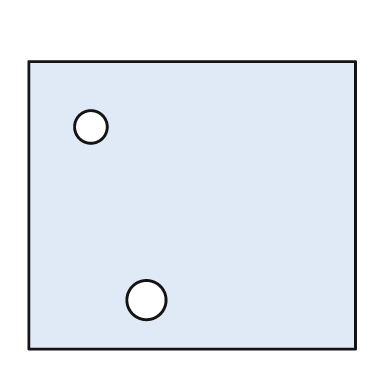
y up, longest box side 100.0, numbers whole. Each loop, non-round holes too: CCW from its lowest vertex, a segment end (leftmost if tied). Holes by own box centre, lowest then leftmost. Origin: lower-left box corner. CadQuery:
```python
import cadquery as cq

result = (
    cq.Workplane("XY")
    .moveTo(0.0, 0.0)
    .lineTo(100.0, 0.0)
    .lineTo(100.0, 88.0)
    .lineTo(0.0, 88.0)
    .close()
    .moveTo(36.0, 15.0)
    .circle(6.0)
    .moveTo(19.0, 68.0)
    .circle(5.0)
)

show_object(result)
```